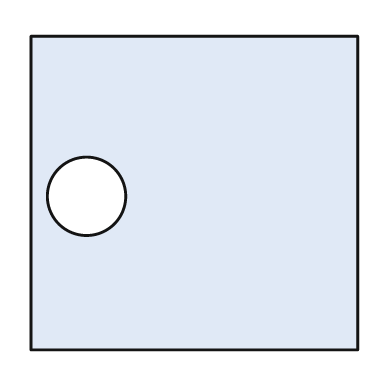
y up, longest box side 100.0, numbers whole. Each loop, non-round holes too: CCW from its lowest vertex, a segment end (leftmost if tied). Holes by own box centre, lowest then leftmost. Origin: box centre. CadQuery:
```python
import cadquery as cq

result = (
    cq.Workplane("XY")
    .moveTo(-50.0, -48.0)
    .lineTo(50.0, -48.0)
    .lineTo(50.0, 48.0)
    .lineTo(-50.0, 48.0)
    .close()
    .moveTo(-33.0, -1.0)
    .circle(12.0)
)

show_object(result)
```